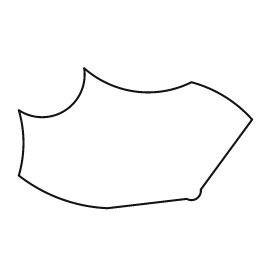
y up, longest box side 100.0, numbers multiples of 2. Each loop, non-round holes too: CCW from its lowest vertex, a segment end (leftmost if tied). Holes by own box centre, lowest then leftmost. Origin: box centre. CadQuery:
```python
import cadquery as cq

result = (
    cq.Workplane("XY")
    .moveTo(-12.0, -30.0)
    .lineTo(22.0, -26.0)
    .threePointArc((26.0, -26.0), (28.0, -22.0))
    .lineTo(50.0, 8.0)
    .threePointArc((38.0, 18.0), (24.0, 24.0))
    .threePointArc((0.0, 20.0), (-22.0, 30.0))
    .threePointArc((-30.0, 12.0), (-50.0, 12.0))
    .threePointArc((-48.0, -2.0), (-50.0, -16.0))
    .threePointArc((-32.0, -26.0), (-12.0, -30.0))
    .close()
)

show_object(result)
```